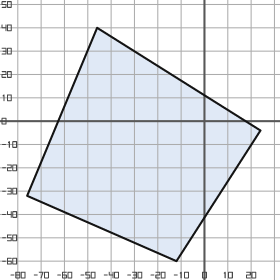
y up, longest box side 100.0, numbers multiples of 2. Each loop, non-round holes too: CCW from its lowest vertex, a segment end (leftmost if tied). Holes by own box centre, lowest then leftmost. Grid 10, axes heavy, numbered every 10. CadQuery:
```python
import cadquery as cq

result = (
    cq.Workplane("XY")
    .moveTo(-12.0, -60.0)
    .lineTo(24.0, -4.0)
    .lineTo(-46.0, 40.0)
    .lineTo(-76.0, -32.0)
    .close()
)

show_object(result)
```